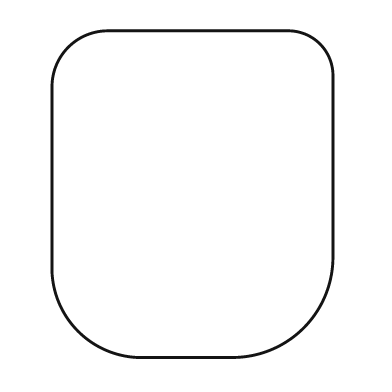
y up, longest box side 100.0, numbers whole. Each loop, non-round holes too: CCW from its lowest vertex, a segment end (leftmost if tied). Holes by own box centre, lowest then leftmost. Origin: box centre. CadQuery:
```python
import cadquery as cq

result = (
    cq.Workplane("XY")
    .moveTo(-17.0, -50.0)
    .lineTo(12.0, -50.0)
    .threePointArc((34.0, -41.0), (43.0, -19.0))
    .lineTo(43.0, 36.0)
    .threePointArc((39.0, 46.0), (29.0, 50.0))
    .lineTo(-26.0, 50.0)
    .threePointArc((-38.0, 45.0), (-43.0, 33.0))
    .lineTo(-43.0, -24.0)
    .threePointArc((-35.0, -42.0), (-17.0, -50.0))
    .close()
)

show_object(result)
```